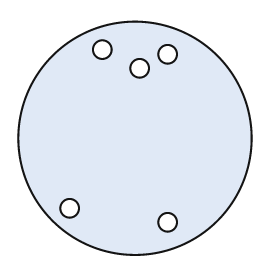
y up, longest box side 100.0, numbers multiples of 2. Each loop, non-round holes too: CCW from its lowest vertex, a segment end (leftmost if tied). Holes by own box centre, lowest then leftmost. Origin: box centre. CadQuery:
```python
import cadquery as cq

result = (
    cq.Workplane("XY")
    .moveTo(0.0, 0.0)
    .circle(50.0)
    .moveTo(14.0, -36.0)
    .circle(4.0)
    .moveTo(-28.0, -30.0)
    .circle(4.0)
    .moveTo(2.0, 30.0)
    .circle(4.0)
    .moveTo(14.0, 36.0)
    .circle(4.0)
    .moveTo(-14.0, 38.0)
    .circle(4.0)
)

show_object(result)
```